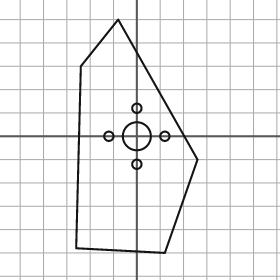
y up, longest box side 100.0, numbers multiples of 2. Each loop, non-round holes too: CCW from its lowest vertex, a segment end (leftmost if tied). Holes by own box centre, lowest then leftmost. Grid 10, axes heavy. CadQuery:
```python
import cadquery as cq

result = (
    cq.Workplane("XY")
    .moveTo(12.0, -50.0)
    .lineTo(26.0, -10.0)
    .lineTo(-8.0, 50.0)
    .lineTo(-24.0, 30.0)
    .lineTo(-26.0, -48.0)
    .close()
    .moveTo(0.0, -12.0)
    .circle(2.0)
    .moveTo(-12.0, 0.0)
    .circle(2.0)
    .moveTo(0.0, 0.0)
    .circle(6.0)
    .moveTo(12.0, 0.0)
    .circle(2.0)
    .moveTo(0.0, 12.0)
    .circle(2.0)
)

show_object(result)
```